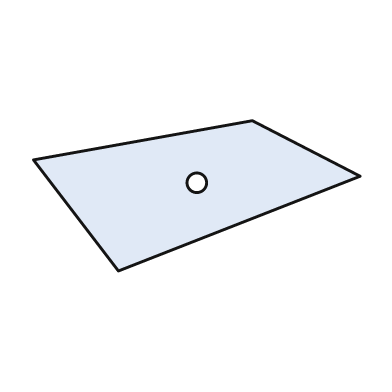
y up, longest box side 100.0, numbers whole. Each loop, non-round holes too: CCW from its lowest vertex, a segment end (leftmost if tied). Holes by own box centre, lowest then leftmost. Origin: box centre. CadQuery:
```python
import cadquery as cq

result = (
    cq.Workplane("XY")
    .moveTo(-24.0, -23.0)
    .lineTo(50.0, 6.0)
    .lineTo(17.0, 23.0)
    .lineTo(-50.0, 11.0)
    .close()
    .moveTo(0.0, 4.0)
    .circle(3.0)
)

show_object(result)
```